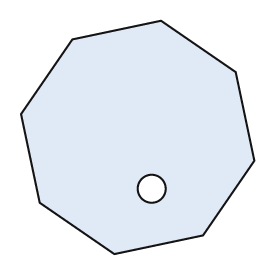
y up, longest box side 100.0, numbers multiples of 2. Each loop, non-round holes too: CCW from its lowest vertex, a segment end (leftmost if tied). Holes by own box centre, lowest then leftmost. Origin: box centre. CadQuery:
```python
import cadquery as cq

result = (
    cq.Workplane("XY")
    .moveTo(-10.0, -50.0)
    .lineTo(28.0, -42.0)
    .lineTo(50.0, -10.0)
    .lineTo(42.0, 28.0)
    .lineTo(10.0, 50.0)
    .lineTo(-28.0, 42.0)
    .lineTo(-50.0, 10.0)
    .lineTo(-42.0, -28.0)
    .close()
    .moveTo(6.0, -22.0)
    .circle(6.0)
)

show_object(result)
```